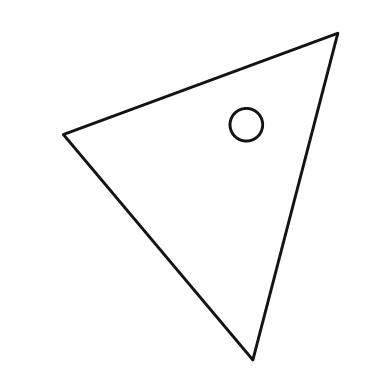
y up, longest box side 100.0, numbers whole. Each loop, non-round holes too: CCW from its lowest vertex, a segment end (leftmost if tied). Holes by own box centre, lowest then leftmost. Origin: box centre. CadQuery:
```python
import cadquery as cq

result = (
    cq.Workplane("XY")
    .moveTo(16.0, -50.0)
    .lineTo(42.0, 50.0)
    .lineTo(-42.0, 19.0)
    .close()
    .moveTo(14.0, 22.0)
    .circle(5.0)
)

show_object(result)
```